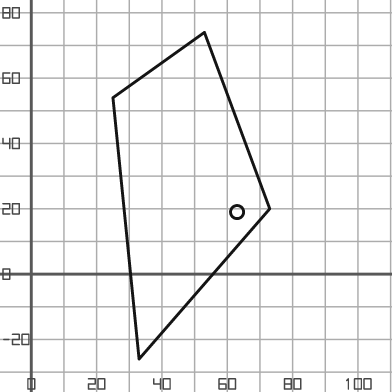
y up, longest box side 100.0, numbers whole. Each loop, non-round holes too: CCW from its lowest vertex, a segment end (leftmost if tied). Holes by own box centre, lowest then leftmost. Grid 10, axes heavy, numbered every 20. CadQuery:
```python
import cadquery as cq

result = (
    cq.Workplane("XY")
    .moveTo(33.0, -26.0)
    .lineTo(73.0, 20.0)
    .lineTo(53.0, 74.0)
    .lineTo(25.0, 54.0)
    .close()
    .moveTo(63.0, 19.0)
    .circle(2.0)
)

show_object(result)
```